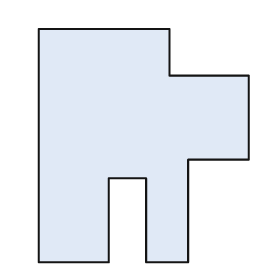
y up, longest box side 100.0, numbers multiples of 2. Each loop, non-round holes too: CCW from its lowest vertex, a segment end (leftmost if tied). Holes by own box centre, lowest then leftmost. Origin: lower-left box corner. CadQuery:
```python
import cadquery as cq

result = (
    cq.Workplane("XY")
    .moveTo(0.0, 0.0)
    .lineTo(30.0, 0.0)
    .lineTo(30.0, 36.0)
    .lineTo(46.0, 36.0)
    .lineTo(46.0, 0.0)
    .lineTo(64.0, 0.0)
    .lineTo(64.0, 44.0)
    .lineTo(90.0, 44.0)
    .lineTo(90.0, 80.0)
    .lineTo(56.0, 80.0)
    .lineTo(56.0, 100.0)
    .lineTo(0.0, 100.0)
    .close()
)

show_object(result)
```